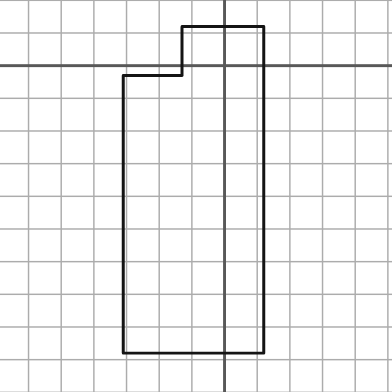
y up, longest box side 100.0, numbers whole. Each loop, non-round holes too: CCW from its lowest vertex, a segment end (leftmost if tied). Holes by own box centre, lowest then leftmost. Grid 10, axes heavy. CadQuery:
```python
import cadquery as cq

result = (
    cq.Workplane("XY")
    .moveTo(-31.0, -88.0)
    .lineTo(12.0, -88.0)
    .lineTo(12.0, 12.0)
    .lineTo(-13.0, 12.0)
    .lineTo(-13.0, -3.0)
    .lineTo(-31.0, -3.0)
    .close()
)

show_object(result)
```